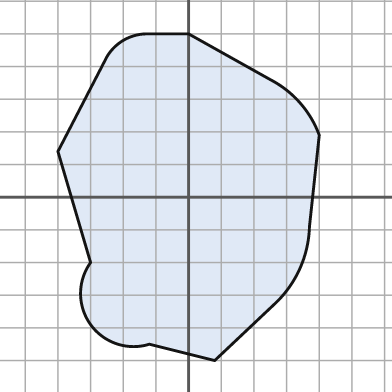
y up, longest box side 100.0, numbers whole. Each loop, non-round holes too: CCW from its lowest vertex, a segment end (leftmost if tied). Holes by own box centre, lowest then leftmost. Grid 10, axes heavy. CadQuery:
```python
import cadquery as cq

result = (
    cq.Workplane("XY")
    .moveTo(8.0, -50.0)
    .lineTo(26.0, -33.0)
    .threePointArc((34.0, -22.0), (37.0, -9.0))
    .lineTo(40.0, 19.0)
    .threePointArc((34.0, 29.0), (25.0, 36.0))
    .lineTo(0.0, 50.0)
    .lineTo(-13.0, 50.0)
    .threePointArc((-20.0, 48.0), (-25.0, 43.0))
    .lineTo(-40.0, 14.0)
    .lineTo(-30.0, -20.0)
    .threePointArc((-30.0, -39.0), (-12.0, -45.0))
    .close()
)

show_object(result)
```